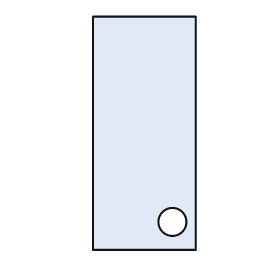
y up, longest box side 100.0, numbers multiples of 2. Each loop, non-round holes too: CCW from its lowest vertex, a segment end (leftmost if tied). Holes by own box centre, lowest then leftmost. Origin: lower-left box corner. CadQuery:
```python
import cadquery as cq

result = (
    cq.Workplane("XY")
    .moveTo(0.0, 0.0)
    .lineTo(44.0, 0.0)
    .lineTo(44.0, 100.0)
    .lineTo(0.0, 100.0)
    .close()
    .moveTo(34.0, 12.0)
    .circle(6.0)
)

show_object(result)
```